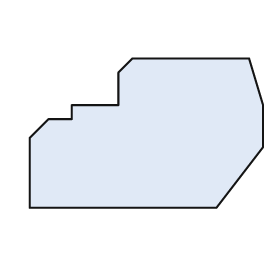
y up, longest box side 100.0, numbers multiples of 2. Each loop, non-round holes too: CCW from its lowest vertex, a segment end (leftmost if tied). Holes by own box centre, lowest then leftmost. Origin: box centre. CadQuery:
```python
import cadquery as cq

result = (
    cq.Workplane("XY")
    .moveTo(-50.0, -32.0)
    .lineTo(30.0, -32.0)
    .lineTo(50.0, -6.0)
    .lineTo(50.0, 12.0)
    .lineTo(44.0, 32.0)
    .lineTo(-6.0, 32.0)
    .lineTo(-12.0, 26.0)
    .lineTo(-12.0, 12.0)
    .lineTo(-32.0, 12.0)
    .lineTo(-32.0, 6.0)
    .lineTo(-42.0, 6.0)
    .lineTo(-50.0, -2.0)
    .close()
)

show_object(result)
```